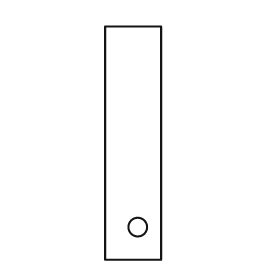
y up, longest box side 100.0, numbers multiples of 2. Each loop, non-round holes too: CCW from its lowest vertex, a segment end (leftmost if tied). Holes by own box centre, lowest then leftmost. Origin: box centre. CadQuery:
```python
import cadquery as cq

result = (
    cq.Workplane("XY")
    .moveTo(-12.0, -50.0)
    .lineTo(12.0, -50.0)
    .lineTo(12.0, 50.0)
    .lineTo(-12.0, 50.0)
    .close()
    .moveTo(2.0, -36.0)
    .circle(4.0)
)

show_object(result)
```